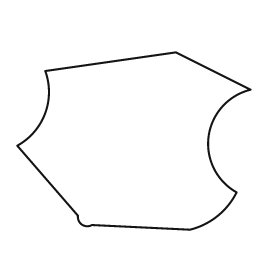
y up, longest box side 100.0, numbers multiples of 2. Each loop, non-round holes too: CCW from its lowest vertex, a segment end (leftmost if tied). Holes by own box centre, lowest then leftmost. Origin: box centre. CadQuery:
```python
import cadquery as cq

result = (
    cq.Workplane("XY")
    .moveTo(24.0, -38.0)
    .threePointArc((36.0, -32.0), (44.0, -22.0))
    .threePointArc((32.0, 2.0), (50.0, 22.0))
    .lineTo(18.0, 38.0)
    .lineTo(-38.0, 30.0)
    .threePointArc((-38.0, 12.0), (-50.0, -2.0))
    .lineTo(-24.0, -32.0)
    .threePointArc((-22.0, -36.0), (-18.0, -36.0))
    .close()
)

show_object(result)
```